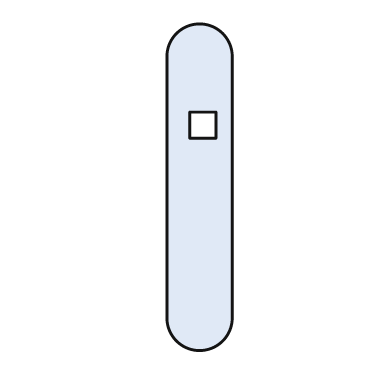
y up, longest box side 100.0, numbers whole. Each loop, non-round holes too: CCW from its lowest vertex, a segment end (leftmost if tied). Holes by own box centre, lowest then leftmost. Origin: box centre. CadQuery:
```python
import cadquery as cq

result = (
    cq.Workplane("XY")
    .moveTo(-10.0, -40.0)
    .threePointArc((0.0, -50.0), (10.0, -40.0))
    .lineTo(10.0, 40.0)
    .threePointArc((0.0, 50.0), (-10.0, 40.0))
    .close()
    .moveTo(-3.0, 15.0)
    .lineTo(5.0, 15.0)
    .lineTo(5.0, 23.0)
    .lineTo(-3.0, 23.0)
    .close()
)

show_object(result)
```